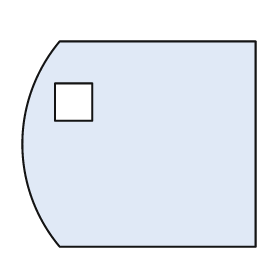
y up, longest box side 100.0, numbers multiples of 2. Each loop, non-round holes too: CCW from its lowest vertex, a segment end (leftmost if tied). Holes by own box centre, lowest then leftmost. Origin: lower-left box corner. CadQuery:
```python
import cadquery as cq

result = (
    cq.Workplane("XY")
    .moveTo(16.0, 0.0)
    .lineTo(100.0, 0.0)
    .lineTo(100.0, 88.0)
    .lineTo(16.0, 88.0)
    .threePointArc((0.0, 44.0), (16.0, 0.0))
    .close()
    .moveTo(14.0, 54.0)
    .lineTo(30.0, 54.0)
    .lineTo(30.0, 70.0)
    .lineTo(14.0, 70.0)
    .close()
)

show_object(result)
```